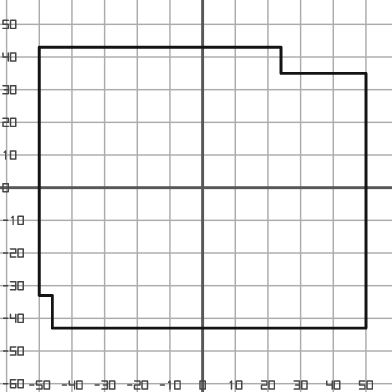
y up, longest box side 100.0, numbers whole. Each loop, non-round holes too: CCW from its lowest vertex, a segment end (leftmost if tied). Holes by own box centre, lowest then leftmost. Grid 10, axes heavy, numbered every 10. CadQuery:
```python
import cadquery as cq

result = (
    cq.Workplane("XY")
    .moveTo(-46.0, -43.0)
    .lineTo(50.0, -43.0)
    .lineTo(50.0, 35.0)
    .lineTo(24.0, 35.0)
    .lineTo(24.0, 43.0)
    .lineTo(-50.0, 43.0)
    .lineTo(-50.0, -33.0)
    .lineTo(-46.0, -33.0)
    .close()
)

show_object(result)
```